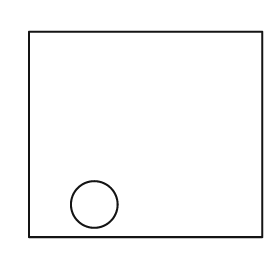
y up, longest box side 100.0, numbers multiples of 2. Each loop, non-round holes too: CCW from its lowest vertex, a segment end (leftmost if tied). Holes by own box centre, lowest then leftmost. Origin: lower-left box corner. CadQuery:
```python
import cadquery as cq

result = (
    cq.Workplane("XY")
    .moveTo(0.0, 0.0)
    .lineTo(100.0, 0.0)
    .lineTo(100.0, 88.0)
    .lineTo(0.0, 88.0)
    .close()
    .moveTo(28.0, 14.0)
    .circle(10.0)
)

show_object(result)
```